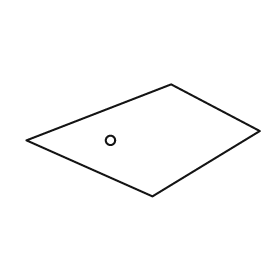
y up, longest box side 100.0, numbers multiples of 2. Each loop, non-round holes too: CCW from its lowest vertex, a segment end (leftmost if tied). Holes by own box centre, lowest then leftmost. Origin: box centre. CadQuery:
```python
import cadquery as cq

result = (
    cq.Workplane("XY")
    .moveTo(4.0, -24.0)
    .lineTo(50.0, 4.0)
    .lineTo(12.0, 24.0)
    .lineTo(-50.0, 0.0)
    .close()
    .moveTo(-14.0, 0.0)
    .circle(2.0)
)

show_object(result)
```